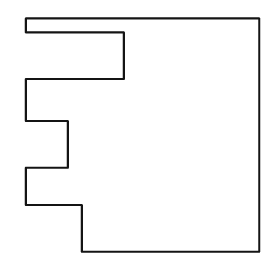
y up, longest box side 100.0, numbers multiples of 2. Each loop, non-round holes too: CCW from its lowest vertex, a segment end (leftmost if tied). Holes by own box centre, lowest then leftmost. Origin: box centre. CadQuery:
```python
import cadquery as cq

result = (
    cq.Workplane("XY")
    .moveTo(-26.0, -50.0)
    .lineTo(50.0, -50.0)
    .lineTo(50.0, 50.0)
    .lineTo(-50.0, 50.0)
    .lineTo(-50.0, 44.0)
    .lineTo(-8.0, 44.0)
    .lineTo(-8.0, 24.0)
    .lineTo(-50.0, 24.0)
    .lineTo(-50.0, 6.0)
    .lineTo(-32.0, 6.0)
    .lineTo(-32.0, -14.0)
    .lineTo(-50.0, -14.0)
    .lineTo(-50.0, -30.0)
    .lineTo(-26.0, -30.0)
    .close()
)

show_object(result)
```